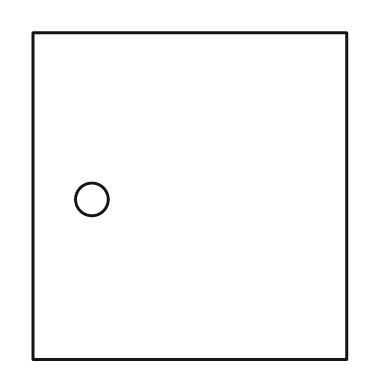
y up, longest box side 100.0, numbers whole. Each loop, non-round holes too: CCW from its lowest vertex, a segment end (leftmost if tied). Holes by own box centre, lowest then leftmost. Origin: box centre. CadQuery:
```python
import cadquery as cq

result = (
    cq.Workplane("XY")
    .moveTo(-48.0, -50.0)
    .lineTo(48.0, -50.0)
    .lineTo(48.0, 50.0)
    .lineTo(-48.0, 50.0)
    .close()
    .moveTo(-30.0, -1.0)
    .circle(5.0)
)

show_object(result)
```